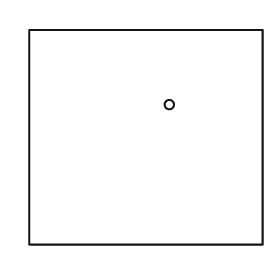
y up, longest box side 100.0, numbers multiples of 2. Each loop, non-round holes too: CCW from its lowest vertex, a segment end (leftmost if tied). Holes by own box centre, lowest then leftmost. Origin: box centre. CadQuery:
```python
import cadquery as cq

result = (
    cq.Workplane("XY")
    .moveTo(-50.0, -46.0)
    .lineTo(50.0, -46.0)
    .lineTo(50.0, 46.0)
    .lineTo(-50.0, 46.0)
    .close()
    .moveTo(10.0, 14.0)
    .circle(2.0)
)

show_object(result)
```